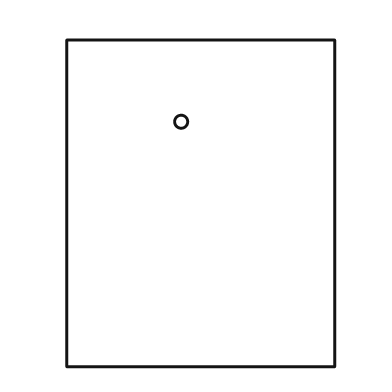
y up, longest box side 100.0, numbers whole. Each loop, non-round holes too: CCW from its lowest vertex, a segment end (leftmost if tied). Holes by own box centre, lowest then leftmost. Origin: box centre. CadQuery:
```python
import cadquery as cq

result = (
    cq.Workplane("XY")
    .moveTo(-41.0, -50.0)
    .lineTo(41.0, -50.0)
    .lineTo(41.0, 50.0)
    .lineTo(-41.0, 50.0)
    .close()
    .moveTo(-6.0, 25.0)
    .circle(2.0)
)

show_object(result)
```